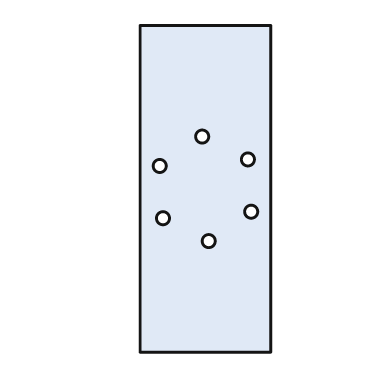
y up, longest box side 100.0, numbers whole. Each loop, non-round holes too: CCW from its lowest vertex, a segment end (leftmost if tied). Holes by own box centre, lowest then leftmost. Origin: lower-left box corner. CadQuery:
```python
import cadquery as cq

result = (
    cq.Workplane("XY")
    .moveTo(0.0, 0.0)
    .lineTo(40.0, 0.0)
    .lineTo(40.0, 100.0)
    .lineTo(0.0, 100.0)
    .close()
    .moveTo(21.0, 34.0)
    .circle(2.0)
    .moveTo(7.0, 41.0)
    .circle(2.0)
    .moveTo(34.0, 43.0)
    .circle(2.0)
    .moveTo(6.0, 57.0)
    .circle(2.0)
    .moveTo(33.0, 59.0)
    .circle(2.0)
    .moveTo(19.0, 66.0)
    .circle(2.0)
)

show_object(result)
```